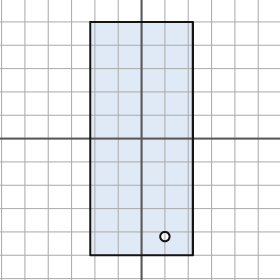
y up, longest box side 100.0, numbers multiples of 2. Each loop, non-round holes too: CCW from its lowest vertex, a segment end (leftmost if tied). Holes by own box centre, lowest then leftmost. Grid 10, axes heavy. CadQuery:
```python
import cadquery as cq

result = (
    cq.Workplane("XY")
    .moveTo(-22.0, -50.0)
    .lineTo(22.0, -50.0)
    .lineTo(22.0, 50.0)
    .lineTo(-22.0, 50.0)
    .close()
    .moveTo(10.0, -42.0)
    .circle(2.0)
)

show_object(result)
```